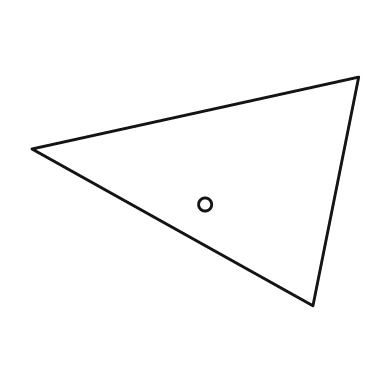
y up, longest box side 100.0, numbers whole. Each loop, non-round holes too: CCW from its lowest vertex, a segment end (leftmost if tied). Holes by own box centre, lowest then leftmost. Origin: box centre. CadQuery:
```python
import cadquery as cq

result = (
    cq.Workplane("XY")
    .moveTo(36.0, -35.0)
    .lineTo(50.0, 35.0)
    .lineTo(-50.0, 13.0)
    .close()
    .moveTo(3.0, -4.0)
    .circle(2.0)
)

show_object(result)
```